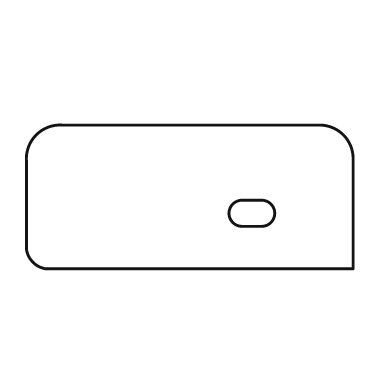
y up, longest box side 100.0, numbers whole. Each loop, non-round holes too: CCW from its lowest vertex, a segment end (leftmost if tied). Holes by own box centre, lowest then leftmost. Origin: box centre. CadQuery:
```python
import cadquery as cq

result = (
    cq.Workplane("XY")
    .moveTo(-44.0, -22.0)
    .lineTo(50.0, -22.0)
    .lineTo(50.0, 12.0)
    .threePointArc((47.0, 19.0), (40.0, 22.0))
    .lineTo(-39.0, 22.0)
    .threePointArc((-47.0, 19.0), (-50.0, 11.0))
    .lineTo(-50.0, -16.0)
    .threePointArc((-48.0, -20.0), (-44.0, -22.0))
    .close()
    .moveTo(16.0, -9.0)
    .lineTo(22.0, -9.0)
    .threePointArc((26.0, -5.0), (22.0, -1.0))
    .lineTo(16.0, -1.0)
    .threePointArc((12.0, -5.0), (16.0, -9.0))
    .close()
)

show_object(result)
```